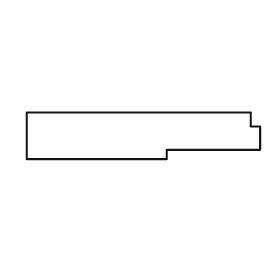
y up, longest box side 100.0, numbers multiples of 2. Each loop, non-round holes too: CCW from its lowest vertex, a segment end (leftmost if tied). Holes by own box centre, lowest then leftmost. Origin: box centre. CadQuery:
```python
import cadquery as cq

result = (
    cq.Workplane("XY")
    .moveTo(-50.0, -10.0)
    .lineTo(10.0, -10.0)
    .lineTo(10.0, -6.0)
    .lineTo(50.0, -6.0)
    .lineTo(50.0, 4.0)
    .lineTo(46.0, 4.0)
    .lineTo(46.0, 10.0)
    .lineTo(-50.0, 10.0)
    .close()
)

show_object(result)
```